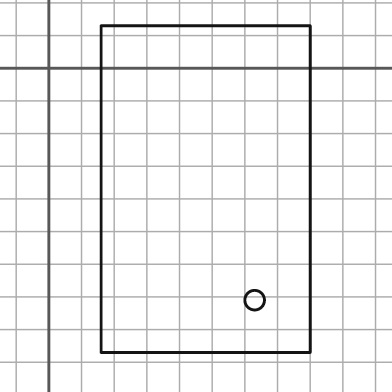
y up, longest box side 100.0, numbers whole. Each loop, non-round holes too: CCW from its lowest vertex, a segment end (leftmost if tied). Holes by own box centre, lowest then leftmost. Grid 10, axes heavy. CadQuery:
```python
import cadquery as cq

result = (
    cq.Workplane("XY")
    .moveTo(16.0, -87.0)
    .lineTo(80.0, -87.0)
    .lineTo(80.0, 13.0)
    .lineTo(16.0, 13.0)
    .close()
    .moveTo(63.0, -71.0)
    .circle(3.0)
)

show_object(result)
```